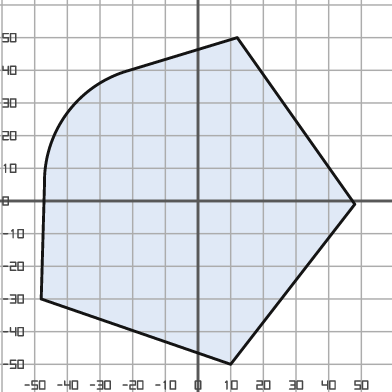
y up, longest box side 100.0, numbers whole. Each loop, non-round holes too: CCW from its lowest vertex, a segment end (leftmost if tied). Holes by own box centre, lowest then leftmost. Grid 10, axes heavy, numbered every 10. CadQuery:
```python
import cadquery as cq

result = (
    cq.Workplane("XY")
    .moveTo(10.0, -50.0)
    .lineTo(48.0, -1.0)
    .lineTo(12.0, 50.0)
    .lineTo(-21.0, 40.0)
    .threePointArc((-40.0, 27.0), (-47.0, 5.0))
    .lineTo(-48.0, -30.0)
    .close()
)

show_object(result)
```